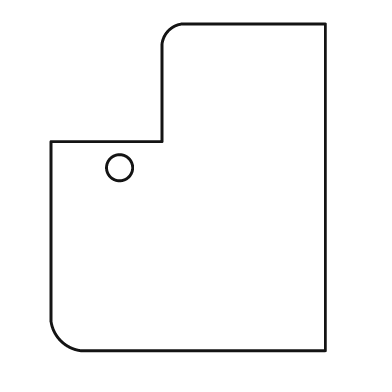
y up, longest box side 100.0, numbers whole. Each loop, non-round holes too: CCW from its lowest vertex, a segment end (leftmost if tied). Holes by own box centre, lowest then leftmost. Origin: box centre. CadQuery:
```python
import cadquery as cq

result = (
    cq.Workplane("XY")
    .moveTo(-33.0, -50.0)
    .lineTo(42.0, -50.0)
    .lineTo(42.0, 50.0)
    .lineTo(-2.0, 50.0)
    .threePointArc((-6.0, 48.0), (-8.0, 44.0))
    .lineTo(-8.0, 14.0)
    .lineTo(-42.0, 14.0)
    .lineTo(-42.0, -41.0)
    .threePointArc((-39.0, -47.0), (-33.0, -50.0))
    .close()
    .moveTo(-21.0, 6.0)
    .circle(4.0)
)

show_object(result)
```